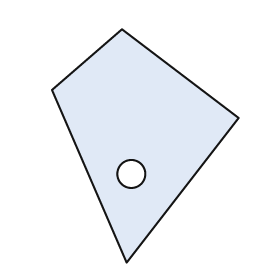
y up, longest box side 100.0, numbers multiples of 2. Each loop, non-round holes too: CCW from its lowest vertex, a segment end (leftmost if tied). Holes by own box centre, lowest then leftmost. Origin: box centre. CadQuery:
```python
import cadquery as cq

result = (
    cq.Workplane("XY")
    .moveTo(-8.0, -50.0)
    .lineTo(40.0, 12.0)
    .lineTo(-10.0, 50.0)
    .lineTo(-40.0, 24.0)
    .close()
    .moveTo(-6.0, -12.0)
    .circle(6.0)
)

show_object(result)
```